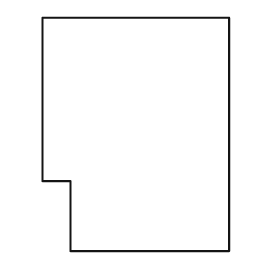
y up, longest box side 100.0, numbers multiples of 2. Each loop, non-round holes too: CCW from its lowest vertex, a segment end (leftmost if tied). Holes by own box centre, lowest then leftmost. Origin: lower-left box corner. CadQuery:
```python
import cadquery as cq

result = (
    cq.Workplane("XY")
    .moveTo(12.0, 0.0)
    .lineTo(80.0, 0.0)
    .lineTo(80.0, 100.0)
    .lineTo(0.0, 100.0)
    .lineTo(0.0, 30.0)
    .lineTo(12.0, 30.0)
    .close()
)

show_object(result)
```